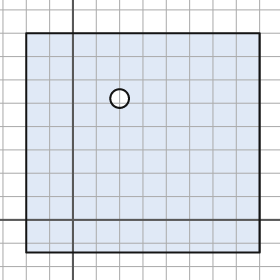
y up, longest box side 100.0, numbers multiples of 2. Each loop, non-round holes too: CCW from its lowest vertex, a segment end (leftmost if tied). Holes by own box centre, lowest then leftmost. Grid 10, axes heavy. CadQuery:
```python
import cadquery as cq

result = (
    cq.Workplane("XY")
    .moveTo(-20.0, -14.0)
    .lineTo(80.0, -14.0)
    .lineTo(80.0, 80.0)
    .lineTo(-20.0, 80.0)
    .close()
    .moveTo(20.0, 52.0)
    .circle(4.0)
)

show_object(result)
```